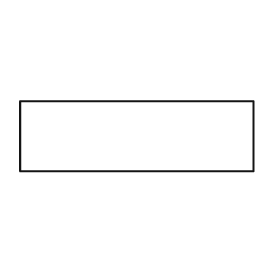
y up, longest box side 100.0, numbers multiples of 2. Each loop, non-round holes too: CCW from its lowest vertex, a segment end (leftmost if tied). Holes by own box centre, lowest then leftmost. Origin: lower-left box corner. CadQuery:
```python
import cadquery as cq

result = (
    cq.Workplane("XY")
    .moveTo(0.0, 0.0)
    .lineTo(100.0, 0.0)
    .lineTo(100.0, 30.0)
    .lineTo(0.0, 30.0)
    .close()
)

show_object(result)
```